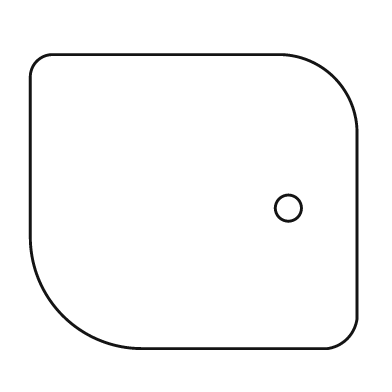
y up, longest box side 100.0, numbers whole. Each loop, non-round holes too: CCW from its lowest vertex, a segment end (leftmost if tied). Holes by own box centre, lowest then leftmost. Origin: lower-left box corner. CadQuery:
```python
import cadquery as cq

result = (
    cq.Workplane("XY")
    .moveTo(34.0, 0.0)
    .lineTo(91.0, 0.0)
    .threePointArc((97.0, 3.0), (100.0, 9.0))
    .lineTo(100.0, 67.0)
    .threePointArc((93.0, 83.0), (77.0, 90.0))
    .lineTo(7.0, 90.0)
    .threePointArc((2.0, 88.0), (0.0, 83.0))
    .lineTo(0.0, 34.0)
    .threePointArc((10.0, 10.0), (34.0, 0.0))
    .close()
    .moveTo(79.0, 43.0)
    .circle(4.0)
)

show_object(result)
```